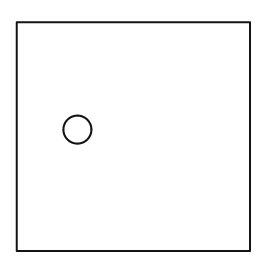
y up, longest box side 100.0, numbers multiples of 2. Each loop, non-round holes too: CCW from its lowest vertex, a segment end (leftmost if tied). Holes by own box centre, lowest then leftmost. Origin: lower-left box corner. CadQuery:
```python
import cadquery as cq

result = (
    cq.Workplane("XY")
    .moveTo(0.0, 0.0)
    .lineTo(100.0, 0.0)
    .lineTo(100.0, 98.0)
    .lineTo(0.0, 98.0)
    .close()
    .moveTo(26.0, 52.0)
    .circle(6.0)
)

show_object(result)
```